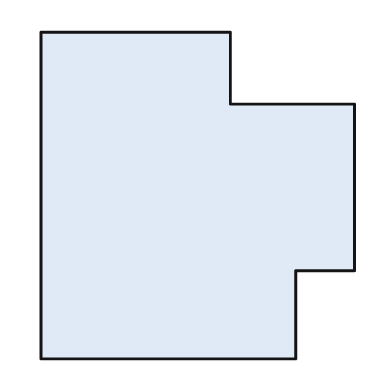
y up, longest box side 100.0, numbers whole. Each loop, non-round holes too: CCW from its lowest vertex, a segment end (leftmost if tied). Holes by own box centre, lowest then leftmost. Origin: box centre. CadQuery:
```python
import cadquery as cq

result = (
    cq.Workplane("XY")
    .moveTo(-48.0, -50.0)
    .lineTo(30.0, -50.0)
    .lineTo(30.0, -23.0)
    .lineTo(48.0, -23.0)
    .lineTo(48.0, 28.0)
    .lineTo(10.0, 28.0)
    .lineTo(10.0, 50.0)
    .lineTo(-48.0, 50.0)
    .close()
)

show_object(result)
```